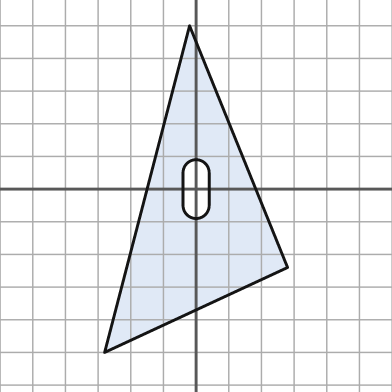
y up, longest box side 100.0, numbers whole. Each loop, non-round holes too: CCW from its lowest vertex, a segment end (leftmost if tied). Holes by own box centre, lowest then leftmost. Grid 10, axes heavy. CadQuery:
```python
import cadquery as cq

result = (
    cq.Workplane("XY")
    .moveTo(-28.0, -50.0)
    .lineTo(28.0, -24.0)
    .lineTo(-2.0, 50.0)
    .close()
    .moveTo(-4.0, -5.0)
    .threePointArc((0.0, -9.0), (4.0, -5.0))
    .lineTo(4.0, 5.0)
    .threePointArc((0.0, 9.0), (-4.0, 5.0))
    .close()
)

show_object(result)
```